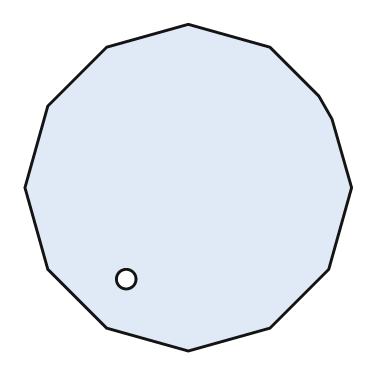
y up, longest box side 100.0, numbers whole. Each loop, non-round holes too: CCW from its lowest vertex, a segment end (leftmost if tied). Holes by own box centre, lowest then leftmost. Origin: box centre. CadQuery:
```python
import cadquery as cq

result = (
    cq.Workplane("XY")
    .moveTo(0.0, -50.0)
    .lineTo(25.0, -43.0)
    .lineTo(43.0, -25.0)
    .lineTo(50.0, 0.0)
    .lineTo(44.0, 21.0)
    .lineTo(40.0, 28.0)
    .lineTo(25.0, 43.0)
    .lineTo(0.0, 50.0)
    .lineTo(-25.0, 43.0)
    .lineTo(-43.0, 25.0)
    .lineTo(-50.0, 0.0)
    .lineTo(-43.0, -25.0)
    .lineTo(-25.0, -43.0)
    .close()
    .moveTo(-19.0, -28.0)
    .circle(3.0)
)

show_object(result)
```